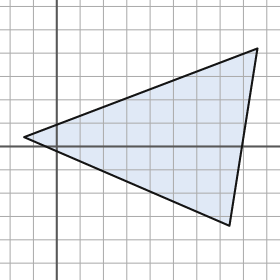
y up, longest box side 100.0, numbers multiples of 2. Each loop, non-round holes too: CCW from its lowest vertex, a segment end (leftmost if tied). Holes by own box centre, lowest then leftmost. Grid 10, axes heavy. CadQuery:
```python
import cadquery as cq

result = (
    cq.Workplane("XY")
    .moveTo(74.0, -34.0)
    .lineTo(86.0, 42.0)
    .lineTo(-14.0, 4.0)
    .close()
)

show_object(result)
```